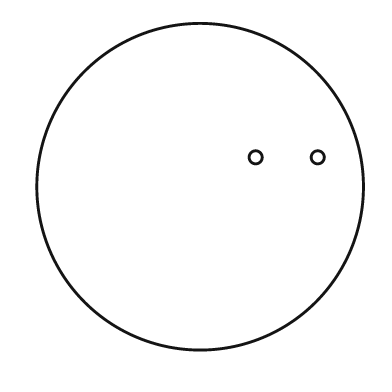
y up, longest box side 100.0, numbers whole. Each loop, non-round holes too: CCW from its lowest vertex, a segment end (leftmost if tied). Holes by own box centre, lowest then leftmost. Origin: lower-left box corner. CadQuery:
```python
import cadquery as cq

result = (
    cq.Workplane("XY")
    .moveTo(50.0, 50.0)
    .circle(50.0)
    .moveTo(67.0, 59.0)
    .circle(2.0)
    .moveTo(86.0, 59.0)
    .circle(2.0)
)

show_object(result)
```